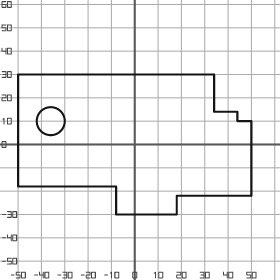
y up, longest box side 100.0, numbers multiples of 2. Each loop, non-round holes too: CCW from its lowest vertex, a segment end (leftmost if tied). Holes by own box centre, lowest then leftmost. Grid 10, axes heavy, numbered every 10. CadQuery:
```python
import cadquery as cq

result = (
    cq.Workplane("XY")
    .moveTo(-8.0, -30.0)
    .lineTo(18.0, -30.0)
    .lineTo(18.0, -22.0)
    .lineTo(50.0, -22.0)
    .lineTo(50.0, 10.0)
    .lineTo(44.0, 10.0)
    .lineTo(44.0, 14.0)
    .lineTo(34.0, 14.0)
    .lineTo(34.0, 30.0)
    .lineTo(-50.0, 30.0)
    .lineTo(-50.0, -18.0)
    .lineTo(-8.0, -18.0)
    .close()
    .moveTo(-36.0, 10.0)
    .circle(6.0)
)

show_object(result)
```